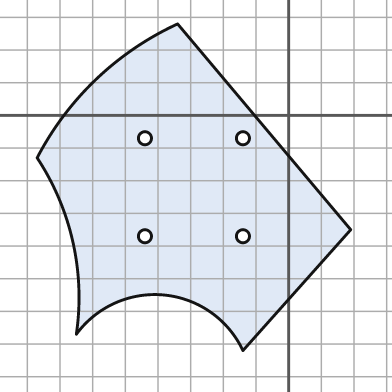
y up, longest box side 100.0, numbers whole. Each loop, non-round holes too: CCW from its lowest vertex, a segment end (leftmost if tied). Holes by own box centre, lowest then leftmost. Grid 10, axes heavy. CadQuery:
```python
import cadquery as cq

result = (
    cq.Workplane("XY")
    .moveTo(-14.0, -72.0)
    .lineTo(19.0, -35.0)
    .lineTo(-34.0, 28.0)
    .threePointArc((-59.0, 11.0), (-77.0, -13.0))
    .threePointArc((-66.0, -39.0), (-65.0, -67.0))
    .threePointArc((-38.0, -55.0), (-14.0, -72.0))
    .close()
    .moveTo(-44.0, -37.0)
    .circle(2.0)
    .moveTo(-14.0, -37.0)
    .circle(2.0)
    .moveTo(-44.0, -7.0)
    .circle(2.0)
    .moveTo(-14.0, -7.0)
    .circle(2.0)
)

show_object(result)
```